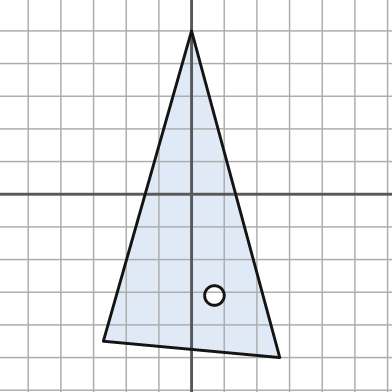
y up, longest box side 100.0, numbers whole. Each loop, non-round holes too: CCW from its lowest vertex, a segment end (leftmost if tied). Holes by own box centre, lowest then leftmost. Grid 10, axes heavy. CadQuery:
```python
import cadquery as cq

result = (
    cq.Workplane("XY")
    .moveTo(27.0, -50.0)
    .lineTo(0.0, 50.0)
    .lineTo(-27.0, -45.0)
    .close()
    .moveTo(7.0, -31.0)
    .circle(3.0)
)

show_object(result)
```